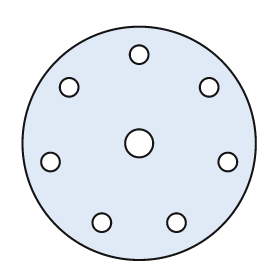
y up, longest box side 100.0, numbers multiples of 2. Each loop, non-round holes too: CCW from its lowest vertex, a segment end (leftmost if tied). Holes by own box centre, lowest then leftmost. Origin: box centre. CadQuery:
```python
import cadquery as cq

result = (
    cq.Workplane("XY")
    .moveTo(0.0, 0.0)
    .circle(50.0)
    .moveTo(-16.0, -34.0)
    .circle(4.0)
    .moveTo(16.0, -34.0)
    .circle(4.0)
    .moveTo(-38.0, -8.0)
    .circle(4.0)
    .moveTo(38.0, -8.0)
    .circle(4.0)
    .moveTo(0.0, 0.0)
    .circle(6.0)
    .moveTo(-30.0, 24.0)
    .circle(4.0)
    .moveTo(30.0, 24.0)
    .circle(4.0)
    .moveTo(0.0, 38.0)
    .circle(4.0)
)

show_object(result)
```